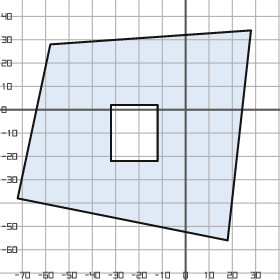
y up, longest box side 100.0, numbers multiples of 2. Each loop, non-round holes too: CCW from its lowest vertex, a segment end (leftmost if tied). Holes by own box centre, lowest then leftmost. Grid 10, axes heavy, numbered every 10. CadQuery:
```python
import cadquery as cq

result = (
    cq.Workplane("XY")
    .moveTo(18.0, -56.0)
    .lineTo(28.0, 34.0)
    .lineTo(-58.0, 28.0)
    .lineTo(-72.0, -38.0)
    .close()
    .moveTo(-32.0, -22.0)
    .lineTo(-12.0, -22.0)
    .lineTo(-12.0, 2.0)
    .lineTo(-32.0, 2.0)
    .close()
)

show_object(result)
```